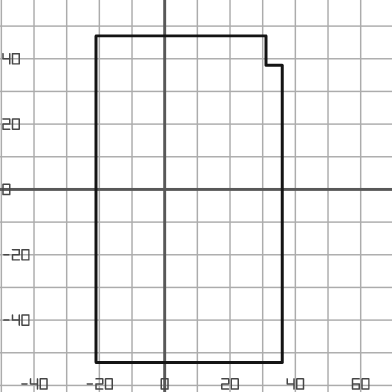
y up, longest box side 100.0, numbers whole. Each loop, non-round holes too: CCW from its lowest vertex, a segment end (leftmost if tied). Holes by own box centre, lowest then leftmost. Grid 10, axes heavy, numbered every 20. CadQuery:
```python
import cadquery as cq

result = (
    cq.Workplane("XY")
    .moveTo(-21.0, -53.0)
    .lineTo(36.0, -53.0)
    .lineTo(36.0, 38.0)
    .lineTo(31.0, 38.0)
    .lineTo(31.0, 47.0)
    .lineTo(-21.0, 47.0)
    .close()
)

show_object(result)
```